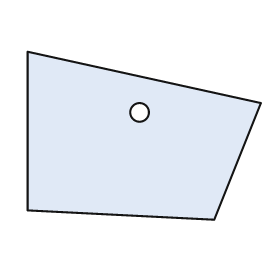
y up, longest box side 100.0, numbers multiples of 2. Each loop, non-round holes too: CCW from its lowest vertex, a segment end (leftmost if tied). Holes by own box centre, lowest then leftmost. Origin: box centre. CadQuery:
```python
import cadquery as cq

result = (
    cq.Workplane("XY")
    .moveTo(30.0, -36.0)
    .lineTo(50.0, 14.0)
    .lineTo(-50.0, 36.0)
    .lineTo(-50.0, -32.0)
    .close()
    .moveTo(-2.0, 10.0)
    .circle(4.0)
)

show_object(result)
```